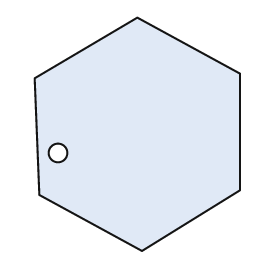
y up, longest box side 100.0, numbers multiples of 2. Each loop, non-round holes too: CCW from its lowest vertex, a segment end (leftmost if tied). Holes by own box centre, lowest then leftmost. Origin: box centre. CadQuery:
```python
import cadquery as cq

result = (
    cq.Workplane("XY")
    .moveTo(2.0, -50.0)
    .lineTo(44.0, -24.0)
    .lineTo(44.0, 26.0)
    .lineTo(0.0, 50.0)
    .lineTo(-44.0, 24.0)
    .lineTo(-42.0, -26.0)
    .close()
    .moveTo(-34.0, -8.0)
    .circle(4.0)
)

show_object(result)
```